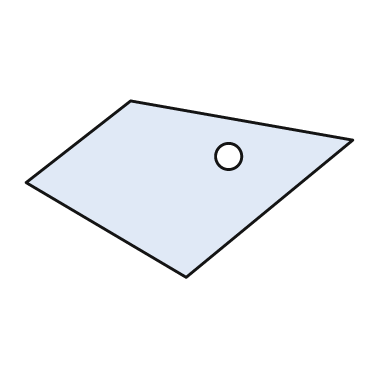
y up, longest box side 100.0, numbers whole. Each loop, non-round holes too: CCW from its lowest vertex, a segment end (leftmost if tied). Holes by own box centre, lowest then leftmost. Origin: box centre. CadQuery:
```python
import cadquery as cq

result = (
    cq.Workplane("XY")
    .moveTo(-1.0, -27.0)
    .lineTo(50.0, 15.0)
    .lineTo(-18.0, 27.0)
    .lineTo(-50.0, 2.0)
    .close()
    .moveTo(12.0, 10.0)
    .circle(4.0)
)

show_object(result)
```